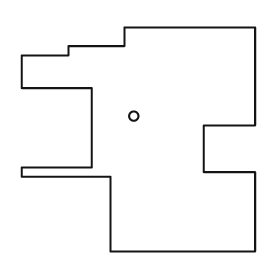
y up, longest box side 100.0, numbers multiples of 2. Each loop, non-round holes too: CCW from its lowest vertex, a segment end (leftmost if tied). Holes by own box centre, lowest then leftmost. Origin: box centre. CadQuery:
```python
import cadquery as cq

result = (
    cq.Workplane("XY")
    .moveTo(-12.0, -48.0)
    .lineTo(50.0, -48.0)
    .lineTo(50.0, -14.0)
    .lineTo(28.0, -14.0)
    .lineTo(28.0, 6.0)
    .lineTo(50.0, 6.0)
    .lineTo(50.0, 48.0)
    .lineTo(-6.0, 48.0)
    .lineTo(-6.0, 40.0)
    .lineTo(-30.0, 40.0)
    .lineTo(-30.0, 36.0)
    .lineTo(-50.0, 36.0)
    .lineTo(-50.0, 22.0)
    .lineTo(-20.0, 22.0)
    .lineTo(-20.0, -12.0)
    .lineTo(-50.0, -12.0)
    .lineTo(-50.0, -16.0)
    .lineTo(-12.0, -16.0)
    .close()
    .moveTo(-2.0, 10.0)
    .circle(2.0)
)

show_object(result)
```